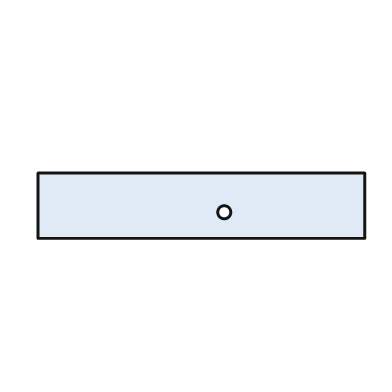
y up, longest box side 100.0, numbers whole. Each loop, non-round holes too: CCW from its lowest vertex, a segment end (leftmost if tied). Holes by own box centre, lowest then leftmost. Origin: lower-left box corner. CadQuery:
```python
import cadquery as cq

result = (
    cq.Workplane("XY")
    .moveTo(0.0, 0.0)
    .lineTo(100.0, 0.0)
    .lineTo(100.0, 20.0)
    .lineTo(0.0, 20.0)
    .close()
    .moveTo(57.0, 8.0)
    .circle(2.0)
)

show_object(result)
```